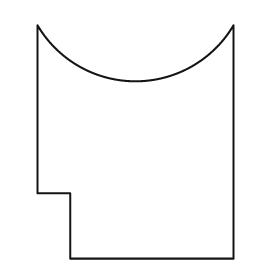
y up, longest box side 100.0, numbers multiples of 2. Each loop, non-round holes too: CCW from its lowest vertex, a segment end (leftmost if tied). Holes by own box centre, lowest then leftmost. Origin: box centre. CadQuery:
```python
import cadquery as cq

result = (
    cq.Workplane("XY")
    .moveTo(-28.0, -50.0)
    .lineTo(42.0, -50.0)
    .lineTo(42.0, 50.0)
    .threePointArc((0.0, 26.0), (-42.0, 50.0))
    .lineTo(-42.0, -22.0)
    .lineTo(-28.0, -22.0)
    .close()
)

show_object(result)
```